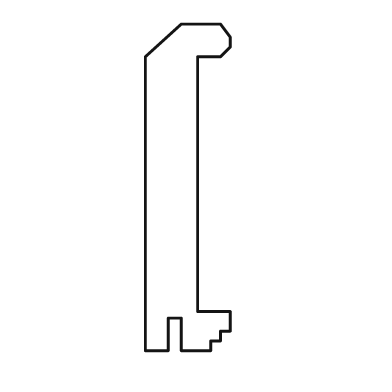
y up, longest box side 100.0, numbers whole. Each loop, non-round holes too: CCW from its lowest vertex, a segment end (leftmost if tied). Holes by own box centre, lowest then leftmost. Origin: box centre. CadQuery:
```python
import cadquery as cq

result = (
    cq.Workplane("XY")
    .moveTo(-13.0, -50.0)
    .lineTo(-6.0, -50.0)
    .lineTo(-6.0, -40.0)
    .lineTo(-2.0, -40.0)
    .lineTo(-2.0, -50.0)
    .lineTo(7.0, -50.0)
    .lineTo(7.0, -47.0)
    .lineTo(10.0, -47.0)
    .lineTo(10.0, -44.0)
    .lineTo(13.0, -44.0)
    .lineTo(13.0, -38.0)
    .lineTo(3.0, -38.0)
    .lineTo(3.0, 40.0)
    .lineTo(10.0, 40.0)
    .lineTo(13.0, 43.0)
    .lineTo(13.0, 46.0)
    .lineTo(10.0, 50.0)
    .lineTo(-2.0, 50.0)
    .lineTo(-13.0, 40.0)
    .close()
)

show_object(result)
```